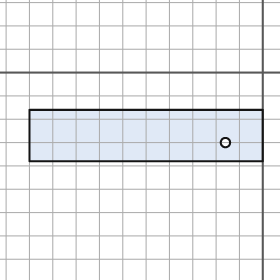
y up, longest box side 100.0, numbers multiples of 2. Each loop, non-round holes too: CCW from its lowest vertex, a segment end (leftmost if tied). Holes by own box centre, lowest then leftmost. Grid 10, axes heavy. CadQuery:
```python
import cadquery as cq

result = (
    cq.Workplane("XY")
    .moveTo(-100.0, -38.0)
    .lineTo(0.0, -38.0)
    .lineTo(0.0, -16.0)
    .lineTo(-100.0, -16.0)
    .close()
    .moveTo(-16.0, -30.0)
    .circle(2.0)
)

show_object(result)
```